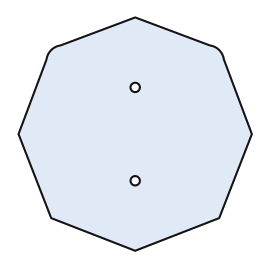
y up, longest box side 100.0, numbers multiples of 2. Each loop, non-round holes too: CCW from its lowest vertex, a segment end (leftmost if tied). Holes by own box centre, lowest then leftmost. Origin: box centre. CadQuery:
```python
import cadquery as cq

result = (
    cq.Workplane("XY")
    .moveTo(0.0, -50.0)
    .lineTo(36.0, -36.0)
    .lineTo(50.0, 0.0)
    .lineTo(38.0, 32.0)
    .threePointArc((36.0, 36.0), (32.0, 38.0))
    .lineTo(0.0, 50.0)
    .lineTo(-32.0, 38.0)
    .threePointArc((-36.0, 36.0), (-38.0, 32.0))
    .lineTo(-50.0, 0.0)
    .lineTo(-36.0, -36.0)
    .close()
    .moveTo(0.0, -20.0)
    .circle(2.0)
    .moveTo(0.0, 20.0)
    .circle(2.0)
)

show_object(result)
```